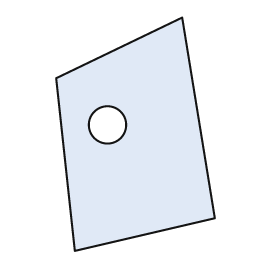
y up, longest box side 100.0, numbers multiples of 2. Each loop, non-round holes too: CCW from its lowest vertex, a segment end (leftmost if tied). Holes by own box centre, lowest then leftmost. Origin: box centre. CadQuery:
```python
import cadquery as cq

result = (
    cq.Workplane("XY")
    .moveTo(-26.0, -50.0)
    .lineTo(34.0, -36.0)
    .lineTo(20.0, 50.0)
    .lineTo(-34.0, 24.0)
    .close()
    .moveTo(-12.0, 4.0)
    .circle(8.0)
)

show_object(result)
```